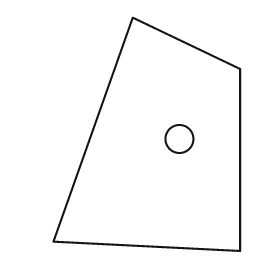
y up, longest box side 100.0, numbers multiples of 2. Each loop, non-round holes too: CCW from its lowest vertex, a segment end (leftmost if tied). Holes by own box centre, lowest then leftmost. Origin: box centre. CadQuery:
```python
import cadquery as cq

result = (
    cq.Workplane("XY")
    .moveTo(40.0, -50.0)
    .lineTo(40.0, 28.0)
    .lineTo(-6.0, 50.0)
    .lineTo(-40.0, -46.0)
    .close()
    .moveTo(14.0, -2.0)
    .circle(6.0)
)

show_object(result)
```